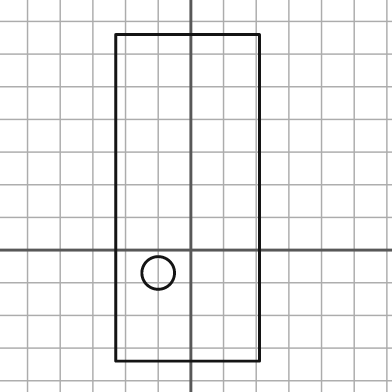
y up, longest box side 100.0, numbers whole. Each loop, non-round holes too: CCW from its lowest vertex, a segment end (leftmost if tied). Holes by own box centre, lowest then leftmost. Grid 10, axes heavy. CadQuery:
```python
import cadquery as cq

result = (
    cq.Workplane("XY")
    .moveTo(-23.0, -34.0)
    .lineTo(21.0, -34.0)
    .lineTo(21.0, 66.0)
    .lineTo(-23.0, 66.0)
    .close()
    .moveTo(-10.0, -7.0)
    .circle(5.0)
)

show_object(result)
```